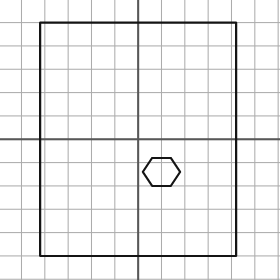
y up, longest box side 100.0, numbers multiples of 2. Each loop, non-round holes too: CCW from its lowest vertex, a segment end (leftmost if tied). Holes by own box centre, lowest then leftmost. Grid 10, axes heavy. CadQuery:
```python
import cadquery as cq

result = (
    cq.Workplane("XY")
    .moveTo(-42.0, -50.0)
    .lineTo(42.0, -50.0)
    .lineTo(42.0, 50.0)
    .lineTo(-42.0, 50.0)
    .close()
    .moveTo(6.0, -20.0)
    .lineTo(14.0, -20.0)
    .lineTo(18.0, -14.0)
    .lineTo(14.0, -8.0)
    .lineTo(6.0, -8.0)
    .lineTo(2.0, -14.0)
    .close()
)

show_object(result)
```